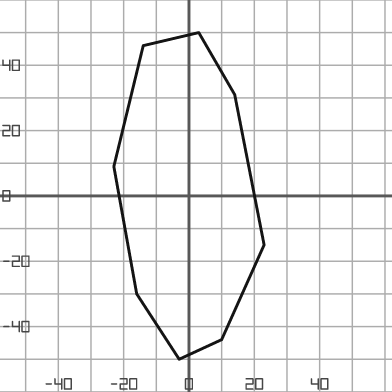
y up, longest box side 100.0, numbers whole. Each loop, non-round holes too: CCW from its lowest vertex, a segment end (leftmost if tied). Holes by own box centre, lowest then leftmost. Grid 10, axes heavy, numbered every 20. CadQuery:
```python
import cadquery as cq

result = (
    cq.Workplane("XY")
    .moveTo(-3.0, -50.0)
    .lineTo(10.0, -44.0)
    .lineTo(23.0, -15.0)
    .lineTo(14.0, 31.0)
    .lineTo(3.0, 50.0)
    .lineTo(-14.0, 46.0)
    .lineTo(-23.0, 9.0)
    .lineTo(-16.0, -30.0)
    .close()
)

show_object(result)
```